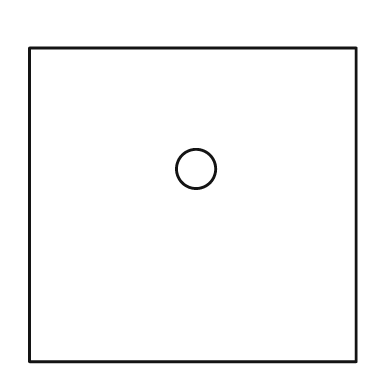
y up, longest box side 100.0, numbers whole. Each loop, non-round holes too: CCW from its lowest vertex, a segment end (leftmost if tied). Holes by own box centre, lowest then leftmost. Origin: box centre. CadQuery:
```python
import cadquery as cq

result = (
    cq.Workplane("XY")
    .moveTo(-50.0, -48.0)
    .lineTo(50.0, -48.0)
    .lineTo(50.0, 48.0)
    .lineTo(-50.0, 48.0)
    .close()
    .moveTo(1.0, 11.0)
    .circle(6.0)
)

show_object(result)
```